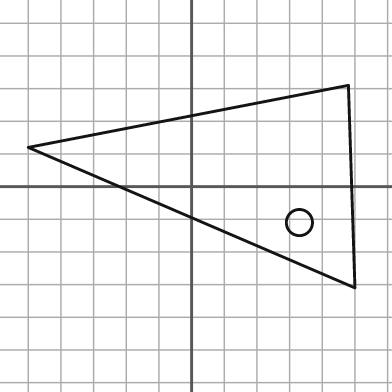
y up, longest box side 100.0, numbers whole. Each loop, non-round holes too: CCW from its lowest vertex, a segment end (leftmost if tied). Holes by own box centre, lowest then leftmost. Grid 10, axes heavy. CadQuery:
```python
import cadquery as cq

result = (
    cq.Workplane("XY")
    .moveTo(50.0, -31.0)
    .lineTo(48.0, 31.0)
    .lineTo(-50.0, 12.0)
    .close()
    .moveTo(33.0, -11.0)
    .circle(4.0)
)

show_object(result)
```